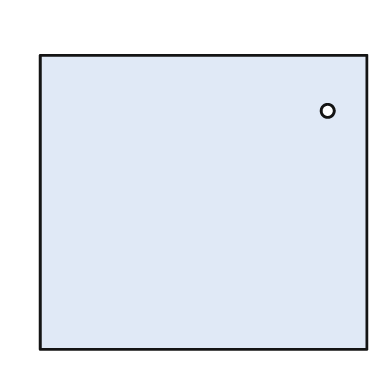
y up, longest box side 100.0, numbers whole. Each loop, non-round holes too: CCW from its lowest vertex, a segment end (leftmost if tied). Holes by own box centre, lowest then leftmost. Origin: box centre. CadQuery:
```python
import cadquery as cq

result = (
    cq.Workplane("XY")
    .moveTo(-50.0, -45.0)
    .lineTo(50.0, -45.0)
    .lineTo(50.0, 45.0)
    .lineTo(-50.0, 45.0)
    .close()
    .moveTo(38.0, 28.0)
    .circle(2.0)
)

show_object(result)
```